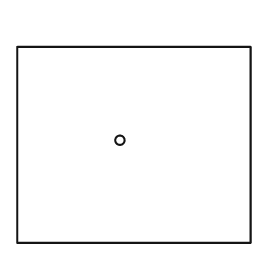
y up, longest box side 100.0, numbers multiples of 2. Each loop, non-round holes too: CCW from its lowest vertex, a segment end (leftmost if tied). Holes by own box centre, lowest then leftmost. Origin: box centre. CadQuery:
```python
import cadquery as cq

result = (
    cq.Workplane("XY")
    .moveTo(-50.0, -42.0)
    .lineTo(50.0, -42.0)
    .lineTo(50.0, 42.0)
    .lineTo(-50.0, 42.0)
    .close()
    .moveTo(-6.0, 2.0)
    .circle(2.0)
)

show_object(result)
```